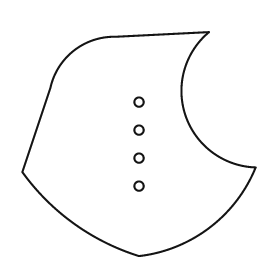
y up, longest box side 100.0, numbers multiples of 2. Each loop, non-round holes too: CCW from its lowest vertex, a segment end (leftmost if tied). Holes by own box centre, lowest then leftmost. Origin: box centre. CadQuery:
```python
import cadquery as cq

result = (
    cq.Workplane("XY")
    .moveTo(0.0, -48.0)
    .threePointArc((30.0, -36.0), (50.0, -10.0))
    .threePointArc((20.0, 12.0), (30.0, 48.0))
    .lineTo(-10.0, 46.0)
    .threePointArc((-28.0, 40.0), (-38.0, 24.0))
    .lineTo(-50.0, -12.0)
    .threePointArc((-28.0, -34.0), (0.0, -48.0))
    .close()
    .moveTo(0.0, -18.0)
    .circle(2.0)
    .moveTo(0.0, -6.0)
    .circle(2.0)
    .moveTo(0.0, 6.0)
    .circle(2.0)
    .moveTo(0.0, 18.0)
    .circle(2.0)
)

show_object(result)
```